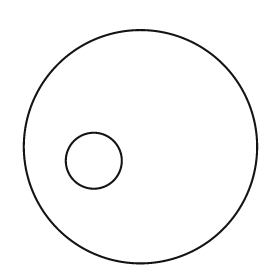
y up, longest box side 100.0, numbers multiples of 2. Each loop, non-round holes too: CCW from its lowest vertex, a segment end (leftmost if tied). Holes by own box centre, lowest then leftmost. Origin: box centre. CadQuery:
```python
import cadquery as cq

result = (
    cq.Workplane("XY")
    .moveTo(0.0, 0.0)
    .circle(50.0)
    .moveTo(-20.0, -6.0)
    .circle(12.0)
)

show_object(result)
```